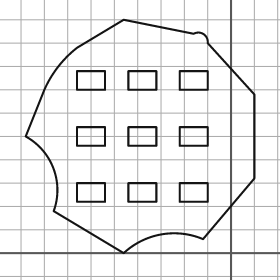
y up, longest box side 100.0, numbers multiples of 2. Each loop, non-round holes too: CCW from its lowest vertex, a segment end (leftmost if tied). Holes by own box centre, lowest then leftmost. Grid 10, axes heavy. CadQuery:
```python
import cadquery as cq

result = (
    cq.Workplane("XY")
    .moveTo(-46.0, 0.0)
    .threePointArc((-30.0, 8.0), (-12.0, 6.0))
    .lineTo(10.0, 32.0)
    .lineTo(10.0, 68.0)
    .lineTo(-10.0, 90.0)
    .threePointArc((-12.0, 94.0), (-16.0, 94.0))
    .lineTo(-46.0, 100.0)
    .lineTo(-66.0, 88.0)
    .threePointArc((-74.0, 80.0), (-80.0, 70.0))
    .lineTo(-88.0, 50.0)
    .threePointArc((-76.0, 36.0), (-76.0, 18.0))
    .close()
    .moveTo(-66.0, 22.0)
    .lineTo(-54.0, 22.0)
    .lineTo(-54.0, 30.0)
    .lineTo(-66.0, 30.0)
    .close()
    .moveTo(-44.0, 22.0)
    .lineTo(-32.0, 22.0)
    .lineTo(-32.0, 30.0)
    .lineTo(-44.0, 30.0)
    .close()
    .moveTo(-22.0, 22.0)
    .lineTo(-10.0, 22.0)
    .lineTo(-10.0, 30.0)
    .lineTo(-22.0, 30.0)
    .close()
    .moveTo(-66.0, 46.0)
    .lineTo(-54.0, 46.0)
    .lineTo(-54.0, 54.0)
    .lineTo(-66.0, 54.0)
    .close()
    .moveTo(-44.0, 46.0)
    .lineTo(-32.0, 46.0)
    .lineTo(-32.0, 54.0)
    .lineTo(-44.0, 54.0)
    .close()
    .moveTo(-22.0, 46.0)
    .lineTo(-10.0, 46.0)
    .lineTo(-10.0, 54.0)
    .lineTo(-22.0, 54.0)
    .close()
    .moveTo(-66.0, 70.0)
    .lineTo(-54.0, 70.0)
    .lineTo(-54.0, 78.0)
    .lineTo(-66.0, 78.0)
    .close()
    .moveTo(-44.0, 70.0)
    .lineTo(-32.0, 70.0)
    .lineTo(-32.0, 78.0)
    .lineTo(-44.0, 78.0)
    .close()
    .moveTo(-22.0, 70.0)
    .lineTo(-10.0, 70.0)
    .lineTo(-10.0, 78.0)
    .lineTo(-22.0, 78.0)
    .close()
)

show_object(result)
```